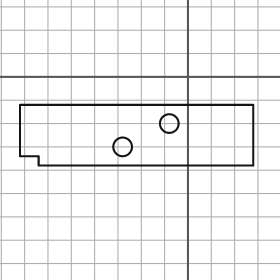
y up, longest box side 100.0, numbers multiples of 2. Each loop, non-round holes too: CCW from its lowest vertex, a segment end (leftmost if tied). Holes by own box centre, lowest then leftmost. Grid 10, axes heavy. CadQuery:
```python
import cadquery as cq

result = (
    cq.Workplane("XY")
    .moveTo(-64.0, -38.0)
    .lineTo(28.0, -38.0)
    .lineTo(28.0, -12.0)
    .lineTo(-72.0, -12.0)
    .lineTo(-72.0, -34.0)
    .lineTo(-64.0, -34.0)
    .close()
    .moveTo(-28.0, -30.0)
    .circle(4.0)
    .moveTo(-8.0, -20.0)
    .circle(4.0)
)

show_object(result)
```